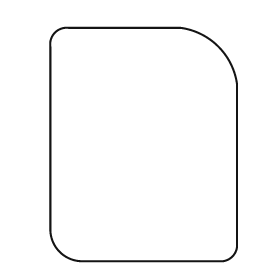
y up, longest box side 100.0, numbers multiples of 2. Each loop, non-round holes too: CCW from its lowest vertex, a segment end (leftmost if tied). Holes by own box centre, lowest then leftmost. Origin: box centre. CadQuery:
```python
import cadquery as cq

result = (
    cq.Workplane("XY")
    .moveTo(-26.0, -50.0)
    .lineTo(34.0, -50.0)
    .threePointArc((38.0, -48.0), (40.0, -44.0))
    .lineTo(40.0, 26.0)
    .threePointArc((32.0, 42.0), (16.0, 50.0))
    .lineTo(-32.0, 50.0)
    .threePointArc((-38.0, 48.0), (-40.0, 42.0))
    .lineTo(-40.0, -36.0)
    .threePointArc((-36.0, -46.0), (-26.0, -50.0))
    .close()
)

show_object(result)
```